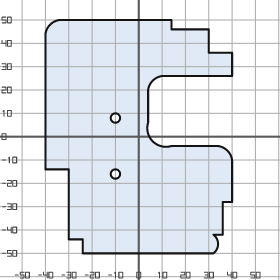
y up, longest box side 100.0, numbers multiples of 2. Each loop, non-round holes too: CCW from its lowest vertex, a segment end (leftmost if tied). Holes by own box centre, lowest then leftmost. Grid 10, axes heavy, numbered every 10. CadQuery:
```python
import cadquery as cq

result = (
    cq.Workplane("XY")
    .moveTo(-24.0, -50.0)
    .lineTo(32.0, -50.0)
    .threePointArc((34.0, -46.0), (32.0, -42.0))
    .lineTo(36.0, -42.0)
    .lineTo(36.0, -28.0)
    .lineTo(40.0, -28.0)
    .lineTo(40.0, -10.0)
    .threePointArc((38.0, -6.0), (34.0, -4.0))
    .lineTo(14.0, -4.0)
    .threePointArc((6.0, -2.0), (4.0, 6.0))
    .lineTo(4.0, 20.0)
    .threePointArc((6.0, 24.0), (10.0, 26.0))
    .lineTo(40.0, 26.0)
    .lineTo(40.0, 36.0)
    .lineTo(30.0, 36.0)
    .lineTo(30.0, 46.0)
    .lineTo(14.0, 46.0)
    .lineTo(14.0, 50.0)
    .lineTo(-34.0, 50.0)
    .threePointArc((-38.0, 48.0), (-40.0, 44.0))
    .lineTo(-40.0, -14.0)
    .lineTo(-30.0, -14.0)
    .lineTo(-30.0, -44.0)
    .lineTo(-24.0, -44.0)
    .close()
    .moveTo(-10.0, -16.0)
    .circle(2.0)
    .moveTo(-10.0, 8.0)
    .circle(2.0)
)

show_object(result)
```